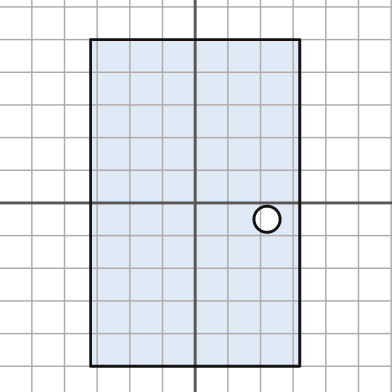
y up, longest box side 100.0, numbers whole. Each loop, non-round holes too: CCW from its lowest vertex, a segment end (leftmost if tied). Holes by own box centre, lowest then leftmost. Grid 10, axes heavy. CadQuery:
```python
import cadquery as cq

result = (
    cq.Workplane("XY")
    .moveTo(-32.0, -50.0)
    .lineTo(32.0, -50.0)
    .lineTo(32.0, 50.0)
    .lineTo(-32.0, 50.0)
    .close()
    .moveTo(22.0, -5.0)
    .circle(4.0)
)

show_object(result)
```